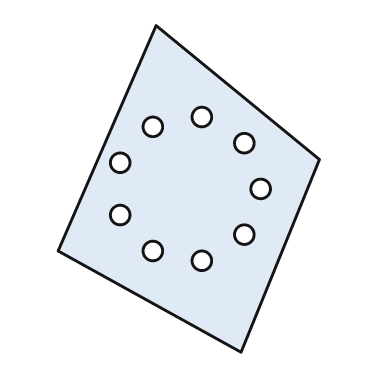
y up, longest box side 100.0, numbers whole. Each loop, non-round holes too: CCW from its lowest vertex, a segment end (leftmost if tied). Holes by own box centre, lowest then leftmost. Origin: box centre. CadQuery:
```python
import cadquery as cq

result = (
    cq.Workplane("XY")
    .moveTo(16.0, -50.0)
    .lineTo(40.0, 9.0)
    .lineTo(-10.0, 50.0)
    .lineTo(-40.0, -19.0)
    .close()
    .moveTo(4.0, -22.0)
    .circle(3.0)
    .moveTo(-11.0, -19.0)
    .circle(3.0)
    .moveTo(17.0, -14.0)
    .circle(3.0)
    .moveTo(-21.0, -8.0)
    .circle(3.0)
    .moveTo(22.0, 0.0)
    .circle(3.0)
    .moveTo(-21.0, 8.0)
    .circle(3.0)
    .moveTo(17.0, 14.0)
    .circle(3.0)
    .moveTo(-11.0, 19.0)
    .circle(3.0)
    .moveTo(4.0, 22.0)
    .circle(3.0)
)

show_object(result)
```